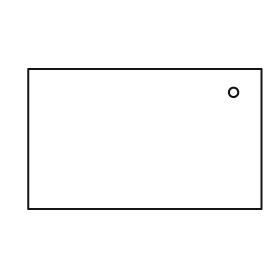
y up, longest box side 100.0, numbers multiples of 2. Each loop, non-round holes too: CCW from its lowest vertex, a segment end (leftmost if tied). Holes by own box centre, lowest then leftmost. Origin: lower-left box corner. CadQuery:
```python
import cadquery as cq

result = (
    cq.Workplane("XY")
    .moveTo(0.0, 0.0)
    .lineTo(100.0, 0.0)
    .lineTo(100.0, 60.0)
    .lineTo(0.0, 60.0)
    .close()
    .moveTo(88.0, 50.0)
    .circle(2.0)
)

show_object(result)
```